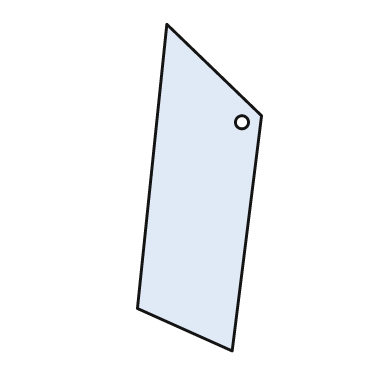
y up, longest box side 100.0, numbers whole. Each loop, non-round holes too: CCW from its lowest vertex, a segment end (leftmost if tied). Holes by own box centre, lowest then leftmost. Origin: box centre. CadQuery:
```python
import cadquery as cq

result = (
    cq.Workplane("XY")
    .moveTo(10.0, -50.0)
    .lineTo(19.0, 22.0)
    .lineTo(-10.0, 50.0)
    .lineTo(-19.0, -37.0)
    .close()
    .moveTo(13.0, 20.0)
    .circle(2.0)
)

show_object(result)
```